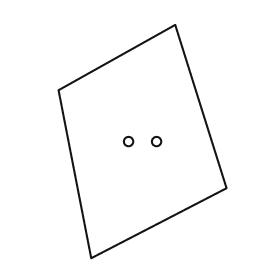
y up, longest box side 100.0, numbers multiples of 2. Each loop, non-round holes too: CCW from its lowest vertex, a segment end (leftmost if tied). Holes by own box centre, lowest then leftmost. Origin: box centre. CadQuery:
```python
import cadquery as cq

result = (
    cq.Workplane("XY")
    .moveTo(-22.0, -50.0)
    .lineTo(36.0, -20.0)
    .lineTo(14.0, 50.0)
    .lineTo(-36.0, 22.0)
    .close()
    .moveTo(-6.0, 0.0)
    .circle(2.0)
    .moveTo(6.0, 0.0)
    .circle(2.0)
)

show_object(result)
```